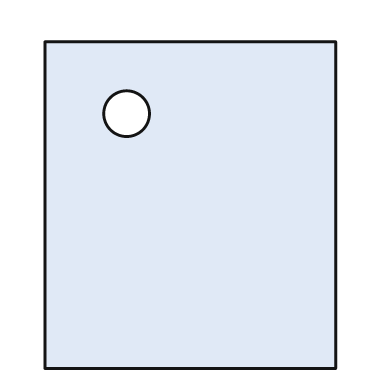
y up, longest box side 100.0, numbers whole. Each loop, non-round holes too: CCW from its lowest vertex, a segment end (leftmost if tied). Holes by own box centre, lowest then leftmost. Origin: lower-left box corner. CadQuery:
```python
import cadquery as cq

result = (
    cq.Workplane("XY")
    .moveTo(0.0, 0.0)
    .lineTo(89.0, 0.0)
    .lineTo(89.0, 100.0)
    .lineTo(0.0, 100.0)
    .close()
    .moveTo(25.0, 78.0)
    .circle(7.0)
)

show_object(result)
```